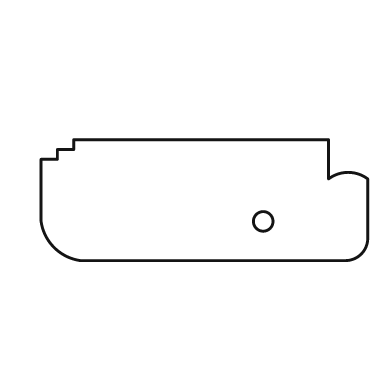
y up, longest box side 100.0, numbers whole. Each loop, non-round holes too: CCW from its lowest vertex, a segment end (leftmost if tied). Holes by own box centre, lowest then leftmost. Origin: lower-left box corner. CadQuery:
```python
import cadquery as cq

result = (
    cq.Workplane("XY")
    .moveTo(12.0, 0.0)
    .lineTo(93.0, 0.0)
    .threePointArc((98.0, 2.0), (100.0, 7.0))
    .lineTo(100.0, 25.0)
    .threePointArc((94.0, 27.0), (88.0, 25.0))
    .lineTo(88.0, 37.0)
    .lineTo(10.0, 37.0)
    .lineTo(10.0, 34.0)
    .lineTo(5.0, 34.0)
    .lineTo(5.0, 31.0)
    .lineTo(0.0, 31.0)
    .lineTo(0.0, 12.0)
    .threePointArc((4.0, 4.0), (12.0, 0.0))
    .close()
    .moveTo(68.0, 12.0)
    .circle(3.0)
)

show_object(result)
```